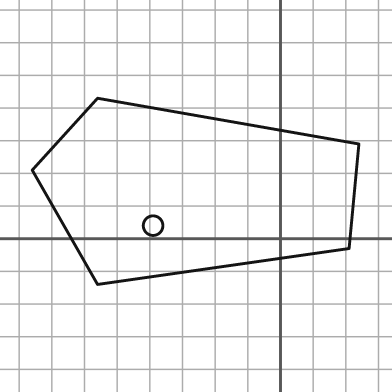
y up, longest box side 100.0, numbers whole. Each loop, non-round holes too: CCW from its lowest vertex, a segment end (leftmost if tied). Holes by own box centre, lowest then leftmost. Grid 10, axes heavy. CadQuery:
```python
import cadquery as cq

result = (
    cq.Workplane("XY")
    .moveTo(-56.0, -14.0)
    .lineTo(21.0, -3.0)
    .lineTo(24.0, 29.0)
    .lineTo(-56.0, 43.0)
    .lineTo(-76.0, 21.0)
    .close()
    .moveTo(-39.0, 4.0)
    .circle(3.0)
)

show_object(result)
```